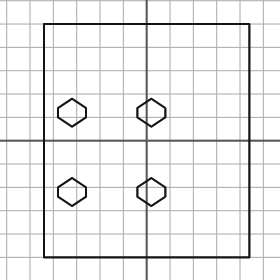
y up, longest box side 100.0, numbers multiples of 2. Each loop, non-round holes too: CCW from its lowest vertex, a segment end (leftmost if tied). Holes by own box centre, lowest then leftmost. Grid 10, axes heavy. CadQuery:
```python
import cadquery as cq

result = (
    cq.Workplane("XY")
    .moveTo(-44.0, -50.0)
    .lineTo(44.0, -50.0)
    .lineTo(44.0, 50.0)
    .lineTo(-44.0, 50.0)
    .close()
    .moveTo(-32.0, -28.0)
    .lineTo(-26.0, -24.0)
    .lineTo(-26.0, -20.0)
    .lineTo(-32.0, -16.0)
    .lineTo(-38.0, -20.0)
    .lineTo(-38.0, -24.0)
    .close()
    .moveTo(2.0, -28.0)
    .lineTo(8.0, -24.0)
    .lineTo(8.0, -20.0)
    .lineTo(2.0, -16.0)
    .lineTo(-4.0, -20.0)
    .lineTo(-4.0, -24.0)
    .close()
    .moveTo(-32.0, 6.0)
    .lineTo(-26.0, 10.0)
    .lineTo(-26.0, 14.0)
    .lineTo(-32.0, 18.0)
    .lineTo(-38.0, 14.0)
    .lineTo(-38.0, 10.0)
    .close()
    .moveTo(2.0, 6.0)
    .lineTo(8.0, 10.0)
    .lineTo(8.0, 14.0)
    .lineTo(2.0, 18.0)
    .lineTo(-4.0, 14.0)
    .lineTo(-4.0, 10.0)
    .close()
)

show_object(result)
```